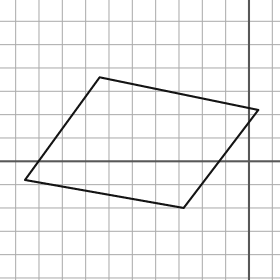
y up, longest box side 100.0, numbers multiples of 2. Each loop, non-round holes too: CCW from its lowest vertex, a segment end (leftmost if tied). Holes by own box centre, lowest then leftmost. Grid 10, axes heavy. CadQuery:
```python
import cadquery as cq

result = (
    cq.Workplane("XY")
    .moveTo(-28.0, -20.0)
    .lineTo(4.0, 22.0)
    .lineTo(-64.0, 36.0)
    .lineTo(-96.0, -8.0)
    .close()
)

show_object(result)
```